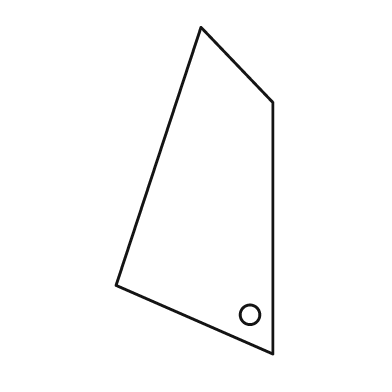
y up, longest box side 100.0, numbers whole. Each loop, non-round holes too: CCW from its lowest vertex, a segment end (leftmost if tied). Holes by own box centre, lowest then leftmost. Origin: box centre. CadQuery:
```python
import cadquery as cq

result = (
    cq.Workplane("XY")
    .moveTo(24.0, -50.0)
    .lineTo(24.0, 27.0)
    .lineTo(2.0, 50.0)
    .lineTo(-24.0, -29.0)
    .close()
    .moveTo(17.0, -38.0)
    .circle(3.0)
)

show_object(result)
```